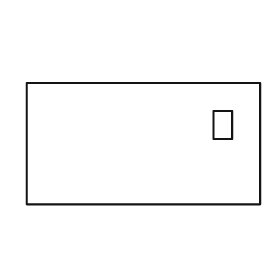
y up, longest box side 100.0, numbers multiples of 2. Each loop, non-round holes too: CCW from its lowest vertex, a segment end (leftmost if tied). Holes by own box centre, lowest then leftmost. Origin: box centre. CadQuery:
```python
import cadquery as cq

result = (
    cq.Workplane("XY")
    .moveTo(-50.0, -26.0)
    .lineTo(50.0, -26.0)
    .lineTo(50.0, 26.0)
    .lineTo(-50.0, 26.0)
    .close()
    .moveTo(30.0, 2.0)
    .lineTo(38.0, 2.0)
    .lineTo(38.0, 14.0)
    .lineTo(30.0, 14.0)
    .close()
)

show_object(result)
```